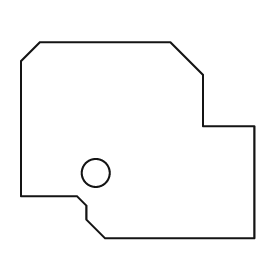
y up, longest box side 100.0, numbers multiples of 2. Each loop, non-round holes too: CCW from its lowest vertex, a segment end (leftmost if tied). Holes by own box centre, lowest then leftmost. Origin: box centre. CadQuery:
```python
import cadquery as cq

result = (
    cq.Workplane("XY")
    .moveTo(-14.0, -42.0)
    .lineTo(50.0, -42.0)
    .lineTo(50.0, 6.0)
    .lineTo(28.0, 6.0)
    .lineTo(28.0, 28.0)
    .lineTo(14.0, 42.0)
    .lineTo(-42.0, 42.0)
    .lineTo(-50.0, 34.0)
    .lineTo(-50.0, -24.0)
    .lineTo(-26.0, -24.0)
    .lineTo(-22.0, -28.0)
    .lineTo(-22.0, -34.0)
    .close()
    .moveTo(-18.0, -14.0)
    .circle(6.0)
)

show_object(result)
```